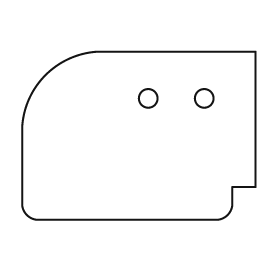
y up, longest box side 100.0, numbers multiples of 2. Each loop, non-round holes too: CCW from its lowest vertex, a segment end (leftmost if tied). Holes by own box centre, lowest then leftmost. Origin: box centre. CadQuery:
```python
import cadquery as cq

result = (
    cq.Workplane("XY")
    .moveTo(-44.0, -36.0)
    .lineTo(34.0, -36.0)
    .threePointArc((38.0, -34.0), (40.0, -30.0))
    .lineTo(40.0, -22.0)
    .lineTo(50.0, -22.0)
    .lineTo(50.0, 36.0)
    .lineTo(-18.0, 36.0)
    .threePointArc((-40.0, 26.0), (-50.0, 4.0))
    .lineTo(-50.0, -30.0)
    .threePointArc((-48.0, -34.0), (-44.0, -36.0))
    .close()
    .moveTo(4.0, 16.0)
    .circle(4.0)
    .moveTo(28.0, 16.0)
    .circle(4.0)
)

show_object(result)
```